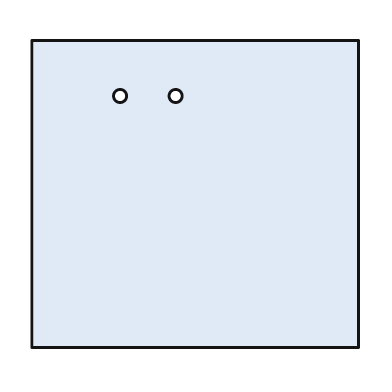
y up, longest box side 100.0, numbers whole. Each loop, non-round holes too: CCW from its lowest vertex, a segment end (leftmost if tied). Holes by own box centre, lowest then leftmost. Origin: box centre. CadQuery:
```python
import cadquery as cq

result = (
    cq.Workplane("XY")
    .moveTo(-50.0, -47.0)
    .lineTo(50.0, -47.0)
    .lineTo(50.0, 47.0)
    .lineTo(-50.0, 47.0)
    .close()
    .moveTo(-23.0, 30.0)
    .circle(2.0)
    .moveTo(-6.0, 30.0)
    .circle(2.0)
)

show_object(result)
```